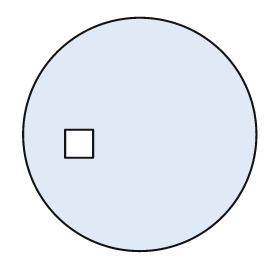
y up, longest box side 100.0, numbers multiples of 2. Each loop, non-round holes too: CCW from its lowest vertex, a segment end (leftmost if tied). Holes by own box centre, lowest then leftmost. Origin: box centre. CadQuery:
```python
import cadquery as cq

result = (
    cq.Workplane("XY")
    .moveTo(0.0, 0.0)
    .circle(50.0)
    .moveTo(-32.0, -10.0)
    .lineTo(-20.0, -10.0)
    .lineTo(-20.0, 2.0)
    .lineTo(-32.0, 2.0)
    .close()
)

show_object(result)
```